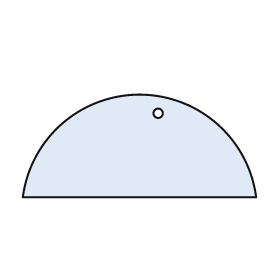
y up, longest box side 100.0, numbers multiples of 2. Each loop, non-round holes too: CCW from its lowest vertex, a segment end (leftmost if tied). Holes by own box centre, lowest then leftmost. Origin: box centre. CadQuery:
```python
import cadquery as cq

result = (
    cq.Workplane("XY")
    .moveTo(-50.0, -22.0)
    .lineTo(50.0, -22.0)
    .threePointArc((0.0, 22.0), (-50.0, -22.0))
    .close()
    .moveTo(8.0, 14.0)
    .circle(2.0)
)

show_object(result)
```